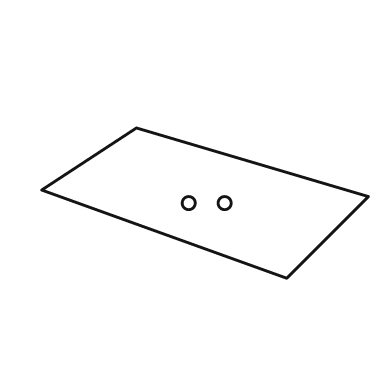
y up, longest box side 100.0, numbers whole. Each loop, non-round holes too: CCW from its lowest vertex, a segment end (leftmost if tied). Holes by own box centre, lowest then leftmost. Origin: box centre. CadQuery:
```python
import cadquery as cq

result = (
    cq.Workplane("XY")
    .moveTo(25.0, -23.0)
    .lineTo(50.0, 2.0)
    .lineTo(-21.0, 23.0)
    .lineTo(-50.0, 4.0)
    .close()
    .moveTo(-5.0, 0.0)
    .circle(2.0)
    .moveTo(6.0, 0.0)
    .circle(2.0)
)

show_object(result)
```